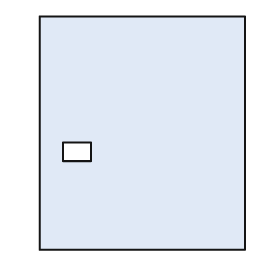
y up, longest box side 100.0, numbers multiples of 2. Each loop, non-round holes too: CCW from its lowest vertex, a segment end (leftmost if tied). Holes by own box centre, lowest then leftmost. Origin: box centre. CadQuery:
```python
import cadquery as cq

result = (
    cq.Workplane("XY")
    .moveTo(-44.0, -50.0)
    .lineTo(44.0, -50.0)
    .lineTo(44.0, 50.0)
    .lineTo(-44.0, 50.0)
    .close()
    .moveTo(-34.0, -12.0)
    .lineTo(-22.0, -12.0)
    .lineTo(-22.0, -4.0)
    .lineTo(-34.0, -4.0)
    .close()
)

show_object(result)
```